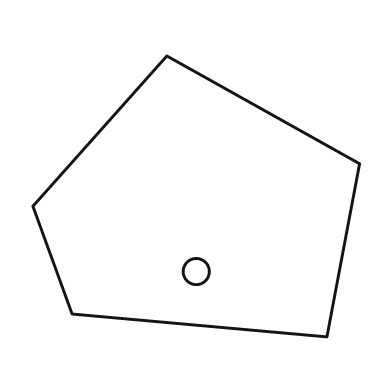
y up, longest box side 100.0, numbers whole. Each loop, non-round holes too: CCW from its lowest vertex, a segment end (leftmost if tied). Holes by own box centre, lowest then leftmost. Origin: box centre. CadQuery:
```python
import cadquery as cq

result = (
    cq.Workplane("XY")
    .moveTo(40.0, -43.0)
    .lineTo(50.0, 10.0)
    .lineTo(-9.0, 43.0)
    .lineTo(-50.0, -3.0)
    .lineTo(-38.0, -36.0)
    .close()
    .moveTo(0.0, -23.0)
    .circle(4.0)
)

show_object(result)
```